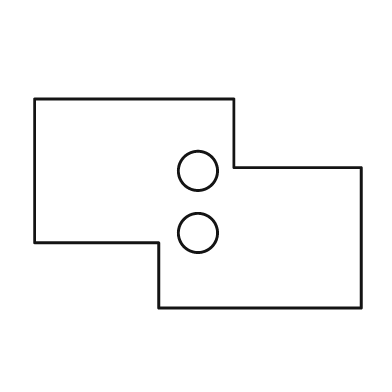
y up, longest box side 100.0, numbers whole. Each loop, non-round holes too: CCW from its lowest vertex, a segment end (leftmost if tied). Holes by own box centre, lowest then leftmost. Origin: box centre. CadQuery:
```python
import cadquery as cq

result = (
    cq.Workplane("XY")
    .moveTo(-12.0, -32.0)
    .lineTo(50.0, -32.0)
    .lineTo(50.0, 11.0)
    .lineTo(11.0, 11.0)
    .lineTo(11.0, 32.0)
    .lineTo(-50.0, 32.0)
    .lineTo(-50.0, -12.0)
    .lineTo(-12.0, -12.0)
    .close()
    .moveTo(0.0, -9.0)
    .circle(6.0)
    .moveTo(0.0, 10.0)
    .circle(6.0)
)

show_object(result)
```